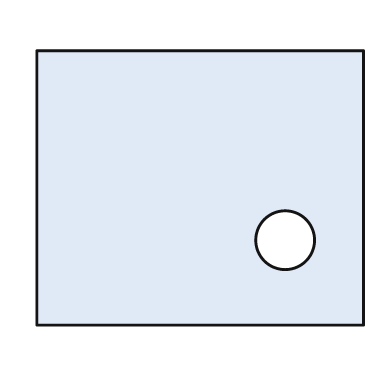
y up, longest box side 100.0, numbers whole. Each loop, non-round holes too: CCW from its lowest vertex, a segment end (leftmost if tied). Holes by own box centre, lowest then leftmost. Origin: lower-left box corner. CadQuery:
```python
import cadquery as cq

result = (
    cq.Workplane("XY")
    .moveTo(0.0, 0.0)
    .lineTo(100.0, 0.0)
    .lineTo(100.0, 84.0)
    .lineTo(0.0, 84.0)
    .close()
    .moveTo(76.0, 26.0)
    .circle(9.0)
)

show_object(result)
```